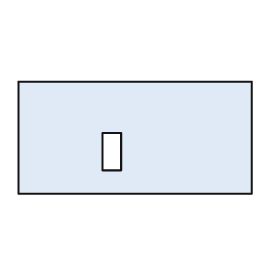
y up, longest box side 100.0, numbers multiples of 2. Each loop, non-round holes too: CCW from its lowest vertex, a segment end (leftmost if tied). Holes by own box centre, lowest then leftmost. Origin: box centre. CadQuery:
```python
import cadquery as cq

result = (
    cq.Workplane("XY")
    .moveTo(-50.0, -24.0)
    .lineTo(50.0, -24.0)
    .lineTo(50.0, 24.0)
    .lineTo(-50.0, 24.0)
    .close()
    .moveTo(-14.0, -14.0)
    .lineTo(-6.0, -14.0)
    .lineTo(-6.0, 2.0)
    .lineTo(-14.0, 2.0)
    .close()
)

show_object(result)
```